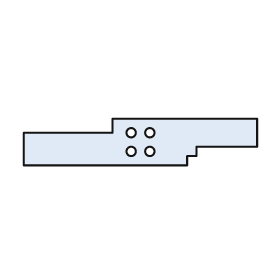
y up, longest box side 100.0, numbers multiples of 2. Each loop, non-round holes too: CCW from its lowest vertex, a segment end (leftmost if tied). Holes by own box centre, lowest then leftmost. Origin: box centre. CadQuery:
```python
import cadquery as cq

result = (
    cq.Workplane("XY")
    .moveTo(-50.0, -10.0)
    .lineTo(20.0, -10.0)
    .lineTo(20.0, -6.0)
    .lineTo(24.0, -6.0)
    .lineTo(24.0, -2.0)
    .lineTo(50.0, -2.0)
    .lineTo(50.0, 10.0)
    .lineTo(-12.0, 10.0)
    .lineTo(-12.0, 4.0)
    .lineTo(-50.0, 4.0)
    .close()
    .moveTo(-4.0, -4.0)
    .circle(2.0)
    .moveTo(4.0, -4.0)
    .circle(2.0)
    .moveTo(-4.0, 4.0)
    .circle(2.0)
    .moveTo(4.0, 4.0)
    .circle(2.0)
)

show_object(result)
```